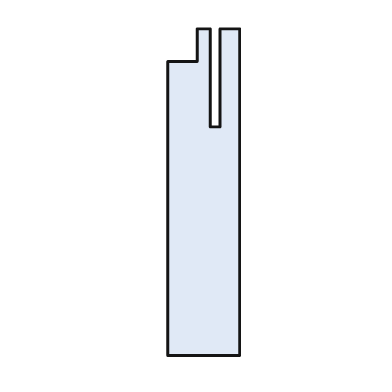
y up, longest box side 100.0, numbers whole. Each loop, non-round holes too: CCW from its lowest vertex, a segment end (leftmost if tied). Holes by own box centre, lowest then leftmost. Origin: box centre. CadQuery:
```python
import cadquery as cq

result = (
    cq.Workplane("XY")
    .moveTo(-11.0, -50.0)
    .lineTo(11.0, -50.0)
    .lineTo(11.0, 50.0)
    .lineTo(5.0, 50.0)
    .lineTo(5.0, 20.0)
    .lineTo(2.0, 20.0)
    .lineTo(2.0, 50.0)
    .lineTo(-2.0, 50.0)
    .lineTo(-2.0, 40.0)
    .lineTo(-11.0, 40.0)
    .close()
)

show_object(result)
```